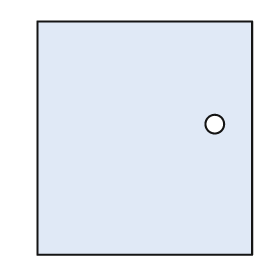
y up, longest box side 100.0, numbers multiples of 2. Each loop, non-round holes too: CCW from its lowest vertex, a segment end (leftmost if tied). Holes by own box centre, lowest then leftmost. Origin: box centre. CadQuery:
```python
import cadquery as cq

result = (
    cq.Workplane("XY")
    .moveTo(-46.0, -50.0)
    .lineTo(46.0, -50.0)
    .lineTo(46.0, 50.0)
    .lineTo(-46.0, 50.0)
    .close()
    .moveTo(30.0, 6.0)
    .circle(4.0)
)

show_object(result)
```